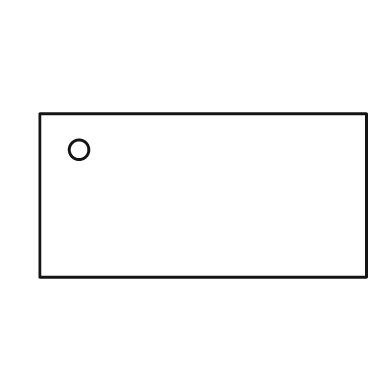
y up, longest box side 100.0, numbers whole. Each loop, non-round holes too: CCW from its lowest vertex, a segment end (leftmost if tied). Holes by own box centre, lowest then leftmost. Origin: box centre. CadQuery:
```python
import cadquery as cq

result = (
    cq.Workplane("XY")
    .moveTo(-50.0, -25.0)
    .lineTo(50.0, -25.0)
    .lineTo(50.0, 25.0)
    .lineTo(-50.0, 25.0)
    .close()
    .moveTo(-38.0, 14.0)
    .circle(3.0)
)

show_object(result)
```